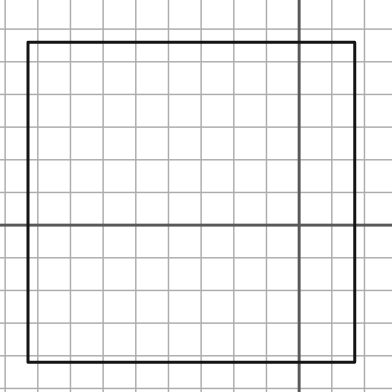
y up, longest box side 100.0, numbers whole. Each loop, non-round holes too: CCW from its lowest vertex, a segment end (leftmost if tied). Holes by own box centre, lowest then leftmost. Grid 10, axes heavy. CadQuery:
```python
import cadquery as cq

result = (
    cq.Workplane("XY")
    .moveTo(-83.0, -42.0)
    .lineTo(17.0, -42.0)
    .lineTo(17.0, 56.0)
    .lineTo(-83.0, 56.0)
    .close()
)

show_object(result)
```